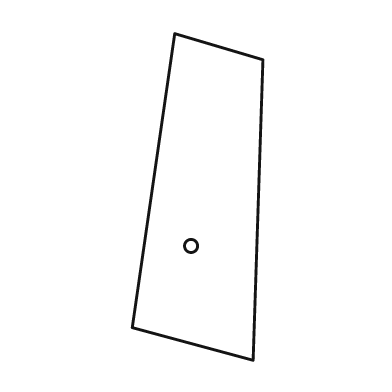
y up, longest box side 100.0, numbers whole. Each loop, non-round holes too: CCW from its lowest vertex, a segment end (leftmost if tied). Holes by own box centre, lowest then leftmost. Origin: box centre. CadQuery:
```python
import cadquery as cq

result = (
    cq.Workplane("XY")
    .moveTo(17.0, -50.0)
    .lineTo(20.0, 42.0)
    .lineTo(-7.0, 50.0)
    .lineTo(-20.0, -40.0)
    .close()
    .moveTo(-2.0, -15.0)
    .circle(2.0)
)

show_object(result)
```